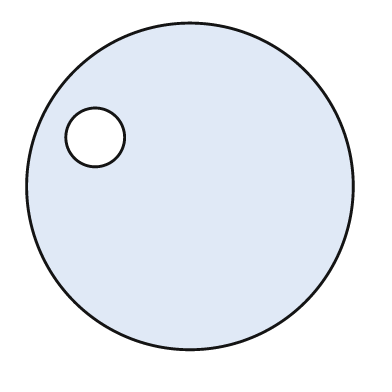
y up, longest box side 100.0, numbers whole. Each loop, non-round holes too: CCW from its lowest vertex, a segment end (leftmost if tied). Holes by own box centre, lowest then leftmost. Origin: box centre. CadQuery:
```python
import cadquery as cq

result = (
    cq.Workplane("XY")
    .moveTo(0.0, 0.0)
    .circle(50.0)
    .moveTo(-29.0, 15.0)
    .circle(9.0)
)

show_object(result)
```